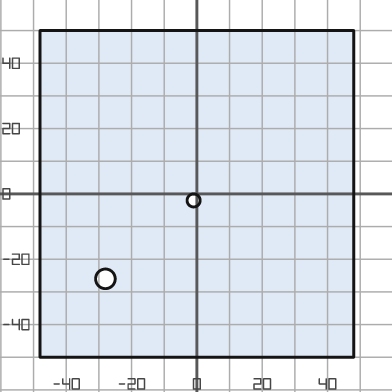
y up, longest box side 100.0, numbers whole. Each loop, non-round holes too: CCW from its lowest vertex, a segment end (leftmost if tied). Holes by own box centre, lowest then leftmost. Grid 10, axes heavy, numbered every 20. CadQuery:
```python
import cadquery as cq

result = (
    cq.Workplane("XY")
    .moveTo(-48.0, -50.0)
    .lineTo(48.0, -50.0)
    .lineTo(48.0, 50.0)
    .lineTo(-48.0, 50.0)
    .close()
    .moveTo(-28.0, -26.0)
    .circle(3.0)
    .moveTo(-1.0, -2.0)
    .circle(2.0)
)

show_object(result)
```